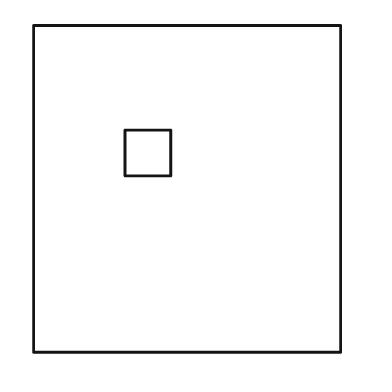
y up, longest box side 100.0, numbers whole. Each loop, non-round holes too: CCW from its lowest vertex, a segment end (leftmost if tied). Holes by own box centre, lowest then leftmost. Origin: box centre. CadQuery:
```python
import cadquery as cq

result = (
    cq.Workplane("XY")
    .moveTo(-47.0, -50.0)
    .lineTo(47.0, -50.0)
    .lineTo(47.0, 50.0)
    .lineTo(-47.0, 50.0)
    .close()
    .moveTo(-19.0, 4.0)
    .lineTo(-5.0, 4.0)
    .lineTo(-5.0, 18.0)
    .lineTo(-19.0, 18.0)
    .close()
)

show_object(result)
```